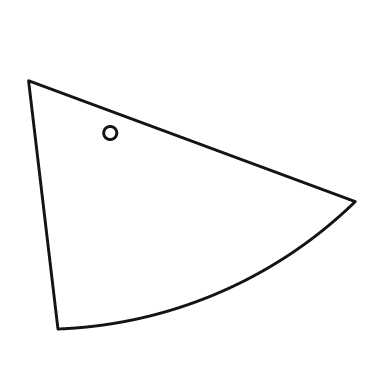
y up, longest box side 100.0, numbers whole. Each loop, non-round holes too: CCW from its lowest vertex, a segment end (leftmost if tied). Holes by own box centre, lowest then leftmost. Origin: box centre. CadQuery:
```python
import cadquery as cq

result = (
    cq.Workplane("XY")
    .moveTo(-41.0, -38.0)
    .threePointArc((8.0, -27.0), (50.0, 1.0))
    .lineTo(-50.0, 38.0)
    .close()
    .moveTo(-25.0, 22.0)
    .circle(2.0)
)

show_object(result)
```